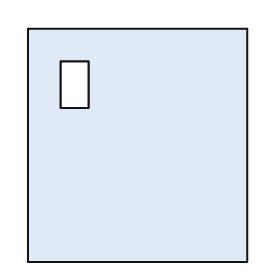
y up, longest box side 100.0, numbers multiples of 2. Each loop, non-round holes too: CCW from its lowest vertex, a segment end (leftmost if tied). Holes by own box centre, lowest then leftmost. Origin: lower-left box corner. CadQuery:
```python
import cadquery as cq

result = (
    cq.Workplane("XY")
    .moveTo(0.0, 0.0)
    .lineTo(94.0, 0.0)
    .lineTo(94.0, 100.0)
    .lineTo(0.0, 100.0)
    .close()
    .moveTo(14.0, 66.0)
    .lineTo(26.0, 66.0)
    .lineTo(26.0, 86.0)
    .lineTo(14.0, 86.0)
    .close()
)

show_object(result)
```